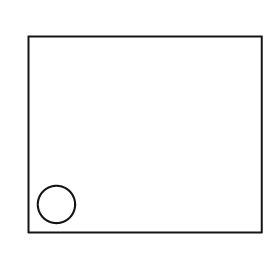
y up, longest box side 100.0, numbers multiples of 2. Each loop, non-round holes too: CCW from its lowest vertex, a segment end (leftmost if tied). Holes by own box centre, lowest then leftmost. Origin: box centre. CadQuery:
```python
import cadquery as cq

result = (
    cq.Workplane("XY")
    .moveTo(-50.0, -42.0)
    .lineTo(50.0, -42.0)
    .lineTo(50.0, 42.0)
    .lineTo(-50.0, 42.0)
    .close()
    .moveTo(-38.0, -30.0)
    .circle(8.0)
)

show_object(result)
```